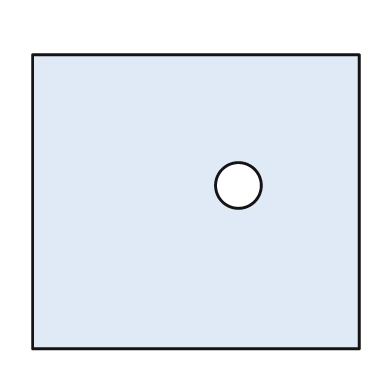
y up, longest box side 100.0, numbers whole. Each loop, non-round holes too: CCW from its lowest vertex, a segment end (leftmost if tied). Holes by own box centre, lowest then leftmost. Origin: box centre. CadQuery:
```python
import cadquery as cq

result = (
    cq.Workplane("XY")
    .moveTo(-50.0, -45.0)
    .lineTo(50.0, -45.0)
    .lineTo(50.0, 45.0)
    .lineTo(-50.0, 45.0)
    .close()
    .moveTo(13.0, 5.0)
    .circle(7.0)
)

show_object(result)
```